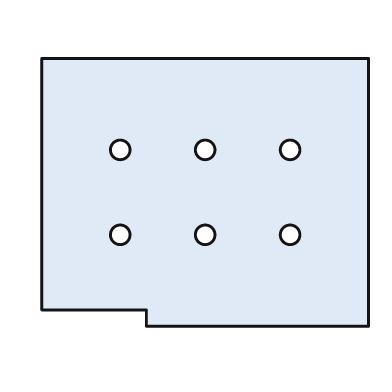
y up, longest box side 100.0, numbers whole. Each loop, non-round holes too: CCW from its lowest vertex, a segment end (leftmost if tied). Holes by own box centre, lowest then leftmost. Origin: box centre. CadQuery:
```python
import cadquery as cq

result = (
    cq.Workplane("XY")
    .moveTo(-18.0, -41.0)
    .lineTo(50.0, -41.0)
    .lineTo(50.0, 41.0)
    .lineTo(-50.0, 41.0)
    .lineTo(-50.0, -36.0)
    .lineTo(-18.0, -36.0)
    .close()
    .moveTo(-26.0, -13.0)
    .circle(3.0)
    .moveTo(0.0, -13.0)
    .circle(3.0)
    .moveTo(26.0, -13.0)
    .circle(3.0)
    .moveTo(-26.0, 13.0)
    .circle(3.0)
    .moveTo(0.0, 13.0)
    .circle(3.0)
    .moveTo(26.0, 13.0)
    .circle(3.0)
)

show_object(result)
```